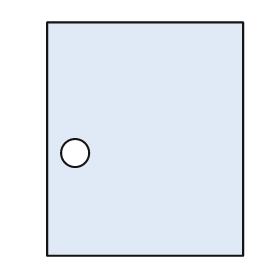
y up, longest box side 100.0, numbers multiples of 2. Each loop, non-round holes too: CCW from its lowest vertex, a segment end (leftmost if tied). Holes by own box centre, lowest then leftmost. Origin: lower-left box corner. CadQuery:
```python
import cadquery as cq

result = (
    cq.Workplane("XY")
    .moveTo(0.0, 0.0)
    .lineTo(84.0, 0.0)
    .lineTo(84.0, 100.0)
    .lineTo(0.0, 100.0)
    .close()
    .moveTo(12.0, 44.0)
    .circle(6.0)
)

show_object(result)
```